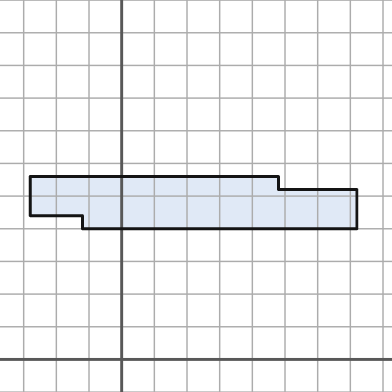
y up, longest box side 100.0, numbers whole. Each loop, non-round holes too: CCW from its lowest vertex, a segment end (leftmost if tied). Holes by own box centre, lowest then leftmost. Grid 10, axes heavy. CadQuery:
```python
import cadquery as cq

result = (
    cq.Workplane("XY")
    .moveTo(-12.0, 40.0)
    .lineTo(72.0, 40.0)
    .lineTo(72.0, 52.0)
    .lineTo(48.0, 52.0)
    .lineTo(48.0, 56.0)
    .lineTo(-28.0, 56.0)
    .lineTo(-28.0, 44.0)
    .lineTo(-12.0, 44.0)
    .close()
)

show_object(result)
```